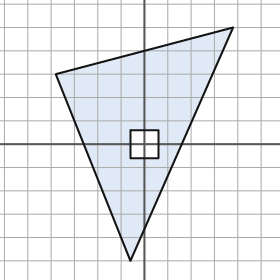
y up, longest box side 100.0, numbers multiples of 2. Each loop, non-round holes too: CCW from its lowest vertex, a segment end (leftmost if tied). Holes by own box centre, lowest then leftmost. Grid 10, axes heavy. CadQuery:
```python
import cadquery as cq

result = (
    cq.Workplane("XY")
    .moveTo(-6.0, -50.0)
    .lineTo(38.0, 50.0)
    .lineTo(-38.0, 30.0)
    .close()
    .moveTo(-6.0, -6.0)
    .lineTo(6.0, -6.0)
    .lineTo(6.0, 6.0)
    .lineTo(-6.0, 6.0)
    .close()
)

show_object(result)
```